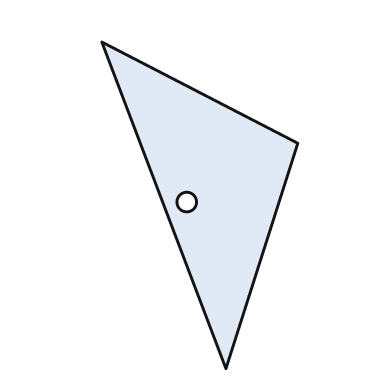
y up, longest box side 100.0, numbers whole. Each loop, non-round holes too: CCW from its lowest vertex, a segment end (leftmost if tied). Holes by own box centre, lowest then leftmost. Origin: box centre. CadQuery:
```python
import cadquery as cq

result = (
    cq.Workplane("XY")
    .moveTo(8.0, -50.0)
    .lineTo(30.0, 19.0)
    .lineTo(-30.0, 50.0)
    .close()
    .moveTo(-4.0, 1.0)
    .circle(3.0)
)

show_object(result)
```